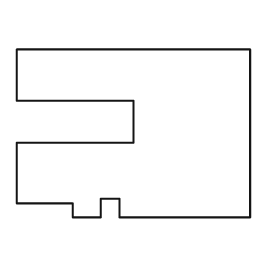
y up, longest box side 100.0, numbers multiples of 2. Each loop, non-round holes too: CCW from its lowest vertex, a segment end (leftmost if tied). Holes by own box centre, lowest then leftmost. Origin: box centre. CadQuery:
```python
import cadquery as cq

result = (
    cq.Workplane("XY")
    .moveTo(-26.0, -36.0)
    .lineTo(-14.0, -36.0)
    .lineTo(-14.0, -28.0)
    .lineTo(-6.0, -28.0)
    .lineTo(-6.0, -36.0)
    .lineTo(50.0, -36.0)
    .lineTo(50.0, 36.0)
    .lineTo(-50.0, 36.0)
    .lineTo(-50.0, 14.0)
    .lineTo(0.0, 14.0)
    .lineTo(0.0, -4.0)
    .lineTo(-50.0, -4.0)
    .lineTo(-50.0, -30.0)
    .lineTo(-26.0, -30.0)
    .close()
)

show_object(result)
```